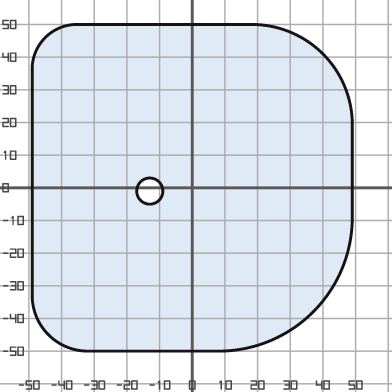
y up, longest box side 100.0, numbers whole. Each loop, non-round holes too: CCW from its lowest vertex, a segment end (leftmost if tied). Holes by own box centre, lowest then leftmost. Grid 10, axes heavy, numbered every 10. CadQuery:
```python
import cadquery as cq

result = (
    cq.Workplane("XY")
    .moveTo(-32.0, -50.0)
    .lineTo(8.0, -50.0)
    .threePointArc((37.0, -38.0), (49.0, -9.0))
    .lineTo(49.0, 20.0)
    .threePointArc((40.0, 41.0), (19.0, 50.0))
    .lineTo(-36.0, 50.0)
    .threePointArc((-45.0, 46.0), (-49.0, 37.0))
    .lineTo(-49.0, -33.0)
    .threePointArc((-44.0, -45.0), (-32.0, -50.0))
    .close()
    .moveTo(-13.0, -1.0)
    .circle(4.0)
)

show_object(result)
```